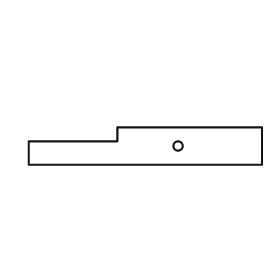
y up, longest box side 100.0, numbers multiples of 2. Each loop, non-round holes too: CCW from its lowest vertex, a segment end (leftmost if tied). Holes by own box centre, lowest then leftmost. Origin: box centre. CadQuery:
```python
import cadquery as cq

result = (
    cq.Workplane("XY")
    .moveTo(-50.0, -8.0)
    .lineTo(50.0, -8.0)
    .lineTo(50.0, 8.0)
    .lineTo(-12.0, 8.0)
    .lineTo(-12.0, 2.0)
    .lineTo(-50.0, 2.0)
    .close()
    .moveTo(14.0, 0.0)
    .circle(2.0)
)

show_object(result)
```